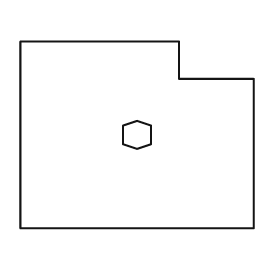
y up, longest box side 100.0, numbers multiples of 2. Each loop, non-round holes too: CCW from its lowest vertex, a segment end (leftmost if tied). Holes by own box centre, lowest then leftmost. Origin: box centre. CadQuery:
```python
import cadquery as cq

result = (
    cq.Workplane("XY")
    .moveTo(-50.0, -40.0)
    .lineTo(50.0, -40.0)
    .lineTo(50.0, 24.0)
    .lineTo(18.0, 24.0)
    .lineTo(18.0, 40.0)
    .lineTo(-50.0, 40.0)
    .close()
    .moveTo(0.0, -6.0)
    .lineTo(6.0, -4.0)
    .lineTo(6.0, 4.0)
    .lineTo(0.0, 6.0)
    .lineTo(-6.0, 4.0)
    .lineTo(-6.0, -4.0)
    .close()
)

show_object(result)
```